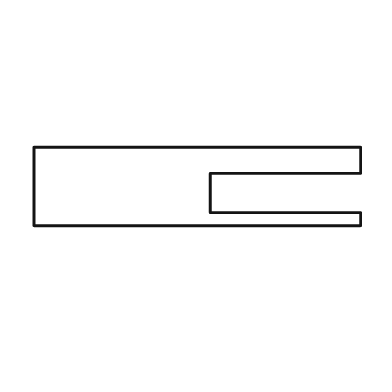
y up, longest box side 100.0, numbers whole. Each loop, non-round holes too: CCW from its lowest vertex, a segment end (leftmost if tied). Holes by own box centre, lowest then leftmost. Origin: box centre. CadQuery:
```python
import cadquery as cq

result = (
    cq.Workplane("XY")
    .moveTo(-50.0, -12.0)
    .lineTo(50.0, -12.0)
    .lineTo(50.0, -8.0)
    .lineTo(4.0, -8.0)
    .lineTo(4.0, 4.0)
    .lineTo(50.0, 4.0)
    .lineTo(50.0, 12.0)
    .lineTo(-50.0, 12.0)
    .close()
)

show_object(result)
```